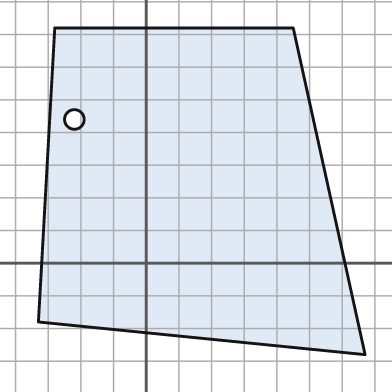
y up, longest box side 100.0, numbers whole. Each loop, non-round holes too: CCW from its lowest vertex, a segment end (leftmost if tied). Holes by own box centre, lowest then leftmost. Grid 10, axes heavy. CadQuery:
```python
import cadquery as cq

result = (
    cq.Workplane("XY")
    .moveTo(67.0, -28.0)
    .lineTo(45.0, 72.0)
    .lineTo(-28.0, 72.0)
    .lineTo(-33.0, -18.0)
    .close()
    .moveTo(-22.0, 44.0)
    .circle(3.0)
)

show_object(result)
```